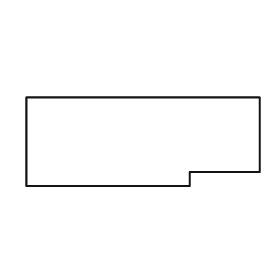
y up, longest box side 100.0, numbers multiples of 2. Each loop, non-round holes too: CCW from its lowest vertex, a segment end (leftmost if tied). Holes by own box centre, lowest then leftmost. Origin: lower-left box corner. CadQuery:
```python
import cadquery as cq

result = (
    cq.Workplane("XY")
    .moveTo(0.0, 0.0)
    .lineTo(70.0, 0.0)
    .lineTo(70.0, 6.0)
    .lineTo(100.0, 6.0)
    .lineTo(100.0, 38.0)
    .lineTo(0.0, 38.0)
    .close()
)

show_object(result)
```